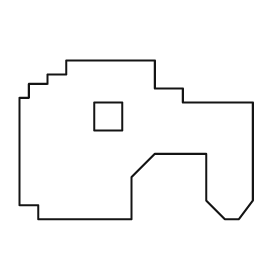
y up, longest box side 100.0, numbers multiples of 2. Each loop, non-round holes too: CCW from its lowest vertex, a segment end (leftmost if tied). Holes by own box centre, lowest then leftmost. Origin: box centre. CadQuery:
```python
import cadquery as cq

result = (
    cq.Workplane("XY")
    .moveTo(-42.0, -34.0)
    .lineTo(-2.0, -34.0)
    .lineTo(-2.0, -16.0)
    .lineTo(8.0, -6.0)
    .lineTo(30.0, -6.0)
    .lineTo(30.0, -26.0)
    .lineTo(38.0, -34.0)
    .lineTo(44.0, -34.0)
    .lineTo(50.0, -26.0)
    .lineTo(50.0, 16.0)
    .lineTo(20.0, 16.0)
    .lineTo(20.0, 22.0)
    .lineTo(8.0, 22.0)
    .lineTo(8.0, 34.0)
    .lineTo(-30.0, 34.0)
    .lineTo(-30.0, 28.0)
    .lineTo(-38.0, 28.0)
    .lineTo(-38.0, 24.0)
    .lineTo(-46.0, 24.0)
    .lineTo(-46.0, 18.0)
    .lineTo(-50.0, 18.0)
    .lineTo(-50.0, -28.0)
    .lineTo(-42.0, -28.0)
    .close()
    .moveTo(-18.0, 4.0)
    .lineTo(-6.0, 4.0)
    .lineTo(-6.0, 16.0)
    .lineTo(-18.0, 16.0)
    .close()
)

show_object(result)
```